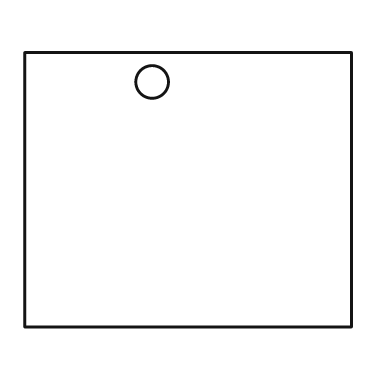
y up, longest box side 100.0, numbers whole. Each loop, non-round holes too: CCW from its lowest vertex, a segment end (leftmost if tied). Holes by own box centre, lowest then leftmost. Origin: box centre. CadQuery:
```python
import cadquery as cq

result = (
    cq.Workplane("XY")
    .moveTo(-50.0, -42.0)
    .lineTo(50.0, -42.0)
    .lineTo(50.0, 42.0)
    .lineTo(-50.0, 42.0)
    .close()
    .moveTo(-11.0, 33.0)
    .circle(5.0)
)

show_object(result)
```